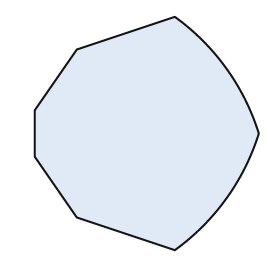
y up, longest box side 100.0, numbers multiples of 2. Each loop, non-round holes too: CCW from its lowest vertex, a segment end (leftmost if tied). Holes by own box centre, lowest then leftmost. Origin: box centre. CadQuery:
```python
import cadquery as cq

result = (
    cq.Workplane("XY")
    .moveTo(12.0, -50.0)
    .threePointArc((34.0, -28.0), (48.0, 0.0))
    .threePointArc((34.0, 28.0), (12.0, 50.0))
    .lineTo(-30.0, 36.0)
    .lineTo(-48.0, 10.0)
    .lineTo(-48.0, -10.0)
    .lineTo(-30.0, -36.0)
    .close()
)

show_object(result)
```